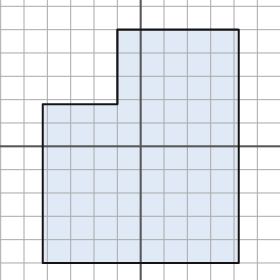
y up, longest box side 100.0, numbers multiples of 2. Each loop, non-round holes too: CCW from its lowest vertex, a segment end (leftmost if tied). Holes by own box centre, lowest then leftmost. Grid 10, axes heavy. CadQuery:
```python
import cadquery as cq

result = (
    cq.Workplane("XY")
    .moveTo(-42.0, -50.0)
    .lineTo(42.0, -50.0)
    .lineTo(42.0, 50.0)
    .lineTo(-10.0, 50.0)
    .lineTo(-10.0, 18.0)
    .lineTo(-42.0, 18.0)
    .close()
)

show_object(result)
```